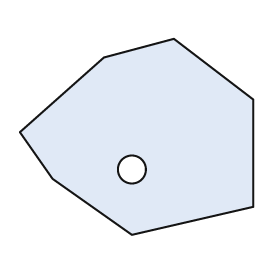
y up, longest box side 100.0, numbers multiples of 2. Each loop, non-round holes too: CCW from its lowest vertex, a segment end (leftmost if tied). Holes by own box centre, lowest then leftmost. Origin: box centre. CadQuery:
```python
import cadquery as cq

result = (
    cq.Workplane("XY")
    .moveTo(-2.0, -42.0)
    .lineTo(50.0, -30.0)
    .lineTo(50.0, 16.0)
    .lineTo(16.0, 42.0)
    .lineTo(-14.0, 34.0)
    .lineTo(-50.0, 2.0)
    .lineTo(-36.0, -18.0)
    .close()
    .moveTo(-2.0, -14.0)
    .circle(6.0)
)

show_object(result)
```